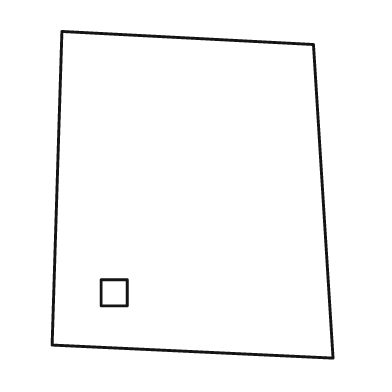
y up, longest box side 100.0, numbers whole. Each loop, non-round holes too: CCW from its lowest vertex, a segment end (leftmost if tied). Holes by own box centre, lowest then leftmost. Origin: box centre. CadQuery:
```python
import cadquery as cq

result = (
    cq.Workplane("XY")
    .moveTo(43.0, -50.0)
    .lineTo(37.0, 46.0)
    .lineTo(-40.0, 50.0)
    .lineTo(-43.0, -46.0)
    .close()
    .moveTo(-28.0, -34.0)
    .lineTo(-20.0, -34.0)
    .lineTo(-20.0, -26.0)
    .lineTo(-28.0, -26.0)
    .close()
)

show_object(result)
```